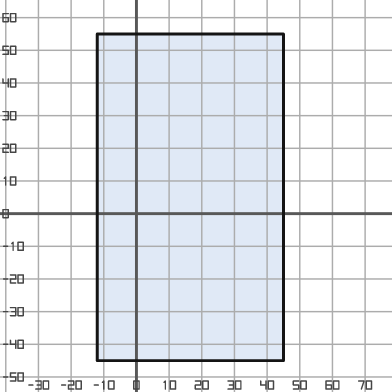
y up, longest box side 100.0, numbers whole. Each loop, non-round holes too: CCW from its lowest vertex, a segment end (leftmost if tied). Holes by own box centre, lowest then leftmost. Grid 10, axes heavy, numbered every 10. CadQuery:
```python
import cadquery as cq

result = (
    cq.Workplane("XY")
    .moveTo(-12.0, -45.0)
    .lineTo(45.0, -45.0)
    .lineTo(45.0, 55.0)
    .lineTo(-12.0, 55.0)
    .close()
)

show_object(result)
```